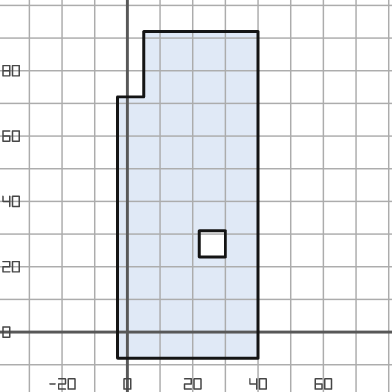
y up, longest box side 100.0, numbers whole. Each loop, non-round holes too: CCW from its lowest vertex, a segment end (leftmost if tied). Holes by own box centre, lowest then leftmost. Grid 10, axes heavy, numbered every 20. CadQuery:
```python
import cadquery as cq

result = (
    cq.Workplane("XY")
    .moveTo(-3.0, -8.0)
    .lineTo(40.0, -8.0)
    .lineTo(40.0, 92.0)
    .lineTo(5.0, 92.0)
    .lineTo(5.0, 72.0)
    .lineTo(-3.0, 72.0)
    .close()
    .moveTo(22.0, 23.0)
    .lineTo(30.0, 23.0)
    .lineTo(30.0, 31.0)
    .lineTo(22.0, 31.0)
    .close()
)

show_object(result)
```